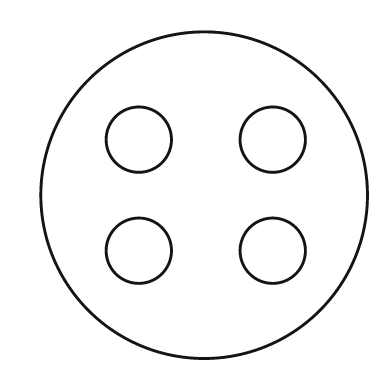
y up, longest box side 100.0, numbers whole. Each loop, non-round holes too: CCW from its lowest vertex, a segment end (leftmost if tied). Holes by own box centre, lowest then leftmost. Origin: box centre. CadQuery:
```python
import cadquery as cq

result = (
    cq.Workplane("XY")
    .moveTo(0.0, 0.0)
    .circle(50.0)
    .moveTo(-20.0, -17.0)
    .circle(10.0)
    .moveTo(21.0, -17.0)
    .circle(10.0)
    .moveTo(-20.0, 17.0)
    .circle(10.0)
    .moveTo(21.0, 17.0)
    .circle(10.0)
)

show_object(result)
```